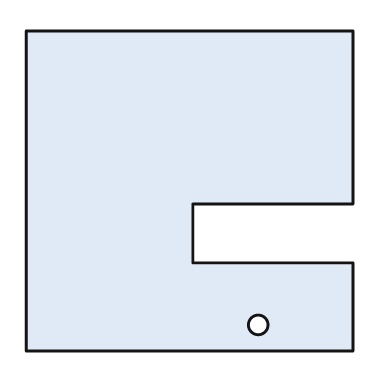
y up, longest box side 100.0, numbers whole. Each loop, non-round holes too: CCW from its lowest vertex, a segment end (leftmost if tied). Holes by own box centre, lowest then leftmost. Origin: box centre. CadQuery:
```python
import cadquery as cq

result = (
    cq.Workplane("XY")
    .moveTo(-50.0, -49.0)
    .lineTo(50.0, -49.0)
    .lineTo(50.0, -22.0)
    .lineTo(1.0, -22.0)
    .lineTo(1.0, -4.0)
    .lineTo(50.0, -4.0)
    .lineTo(50.0, 49.0)
    .lineTo(-50.0, 49.0)
    .close()
    .moveTo(21.0, -41.0)
    .circle(3.0)
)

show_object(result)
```